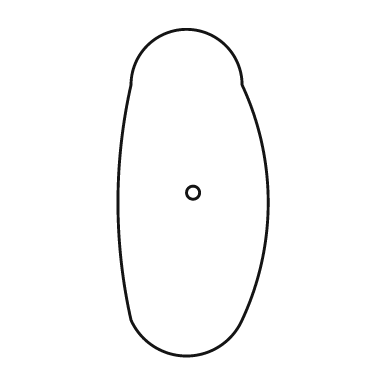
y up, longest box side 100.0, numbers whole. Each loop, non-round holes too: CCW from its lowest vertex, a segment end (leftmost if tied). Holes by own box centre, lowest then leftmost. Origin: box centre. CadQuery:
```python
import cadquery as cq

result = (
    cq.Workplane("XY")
    .moveTo(-19.0, -39.0)
    .threePointArc((-2.0, -50.0), (15.0, -39.0))
    .threePointArc((23.0, -3.0), (15.0, 33.0))
    .threePointArc((-2.0, 50.0), (-19.0, 33.0))
    .threePointArc((-23.0, -3.0), (-19.0, -39.0))
    .close()
    .moveTo(0.0, 0.0)
    .circle(2.0)
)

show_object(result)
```